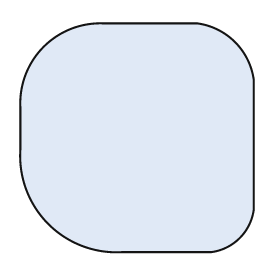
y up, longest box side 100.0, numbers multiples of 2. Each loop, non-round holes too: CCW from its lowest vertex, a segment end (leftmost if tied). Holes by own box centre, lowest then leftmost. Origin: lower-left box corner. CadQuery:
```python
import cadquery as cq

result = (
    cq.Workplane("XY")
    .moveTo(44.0, 0.0)
    .lineTo(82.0, 0.0)
    .threePointArc((94.0, 6.0), (100.0, 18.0))
    .lineTo(100.0, 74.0)
    .threePointArc((92.0, 90.0), (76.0, 98.0))
    .lineTo(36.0, 98.0)
    .threePointArc((10.0, 88.0), (0.0, 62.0))
    .lineTo(0.0, 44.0)
    .threePointArc((12.0, 12.0), (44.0, 0.0))
    .close()
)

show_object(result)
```